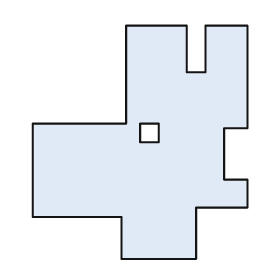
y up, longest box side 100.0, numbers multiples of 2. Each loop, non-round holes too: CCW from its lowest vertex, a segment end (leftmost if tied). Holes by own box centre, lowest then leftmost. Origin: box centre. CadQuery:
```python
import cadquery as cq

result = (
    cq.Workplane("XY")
    .moveTo(-8.0, -50.0)
    .lineTo(24.0, -50.0)
    .lineTo(24.0, -28.0)
    .lineTo(46.0, -28.0)
    .lineTo(46.0, -16.0)
    .lineTo(36.0, -16.0)
    .lineTo(36.0, 6.0)
    .lineTo(46.0, 6.0)
    .lineTo(46.0, 50.0)
    .lineTo(28.0, 50.0)
    .lineTo(28.0, 30.0)
    .lineTo(20.0, 30.0)
    .lineTo(20.0, 50.0)
    .lineTo(-6.0, 50.0)
    .lineTo(-6.0, 8.0)
    .lineTo(-46.0, 8.0)
    .lineTo(-46.0, -32.0)
    .lineTo(-8.0, -32.0)
    .close()
    .moveTo(0.0, 0.0)
    .lineTo(8.0, 0.0)
    .lineTo(8.0, 8.0)
    .lineTo(0.0, 8.0)
    .close()
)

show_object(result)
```